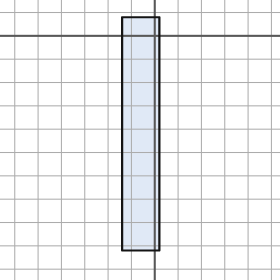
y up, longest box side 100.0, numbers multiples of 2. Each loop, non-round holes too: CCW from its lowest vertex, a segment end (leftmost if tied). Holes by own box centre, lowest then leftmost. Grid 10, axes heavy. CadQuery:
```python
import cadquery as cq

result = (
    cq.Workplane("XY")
    .moveTo(-14.0, -92.0)
    .lineTo(2.0, -92.0)
    .lineTo(2.0, 8.0)
    .lineTo(-14.0, 8.0)
    .close()
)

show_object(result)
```